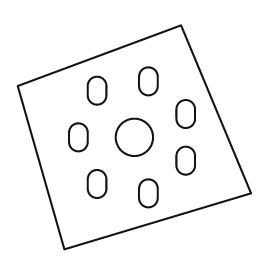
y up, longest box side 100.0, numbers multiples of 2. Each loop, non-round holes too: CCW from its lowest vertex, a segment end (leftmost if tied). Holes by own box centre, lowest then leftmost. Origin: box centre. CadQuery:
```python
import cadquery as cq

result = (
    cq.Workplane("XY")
    .moveTo(-30.0, -48.0)
    .lineTo(50.0, -24.0)
    .lineTo(20.0, 48.0)
    .lineTo(-50.0, 22.0)
    .close()
    .moveTo(2.0, -26.0)
    .threePointArc((6.0, -30.0), (10.0, -26.0))
    .lineTo(10.0, -22.0)
    .threePointArc((6.0, -18.0), (2.0, -22.0))
    .close()
    .moveTo(-20.0, -22.0)
    .threePointArc((-16.0, -26.0), (-12.0, -22.0))
    .lineTo(-12.0, -18.0)
    .threePointArc((-16.0, -14.0), (-20.0, -18.0))
    .close()
    .moveTo(18.0, -12.0)
    .threePointArc((22.0, -16.0), (26.0, -12.0))
    .lineTo(26.0, -8.0)
    .threePointArc((22.0, -4.0), (18.0, -8.0))
    .close()
    .moveTo(-28.0, -2.0)
    .threePointArc((-24.0, -6.0), (-20.0, -2.0))
    .lineTo(-20.0, 2.0)
    .threePointArc((-24.0, 6.0), (-28.0, 2.0))
    .close()
    .moveTo(0.0, 0.0)
    .circle(8.0)
    .moveTo(18.0, 8.0)
    .threePointArc((22.0, 4.0), (26.0, 8.0))
    .lineTo(26.0, 12.0)
    .threePointArc((22.0, 16.0), (18.0, 12.0))
    .close()
    .moveTo(-20.0, 18.0)
    .threePointArc((-16.0, 14.0), (-12.0, 18.0))
    .lineTo(-12.0, 22.0)
    .threePointArc((-16.0, 26.0), (-20.0, 22.0))
    .close()
    .moveTo(2.0, 22.0)
    .threePointArc((6.0, 18.0), (10.0, 22.0))
    .lineTo(10.0, 26.0)
    .threePointArc((6.0, 30.0), (2.0, 26.0))
    .close()
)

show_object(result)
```